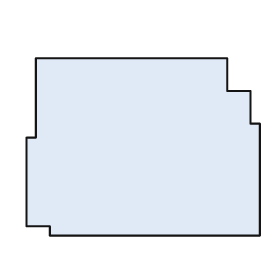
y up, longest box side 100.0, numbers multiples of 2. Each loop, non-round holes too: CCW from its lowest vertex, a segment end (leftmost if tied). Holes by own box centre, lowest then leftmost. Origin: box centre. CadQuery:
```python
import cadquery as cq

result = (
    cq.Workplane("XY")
    .moveTo(-40.0, -38.0)
    .lineTo(50.0, -38.0)
    .lineTo(50.0, 10.0)
    .lineTo(46.0, 10.0)
    .lineTo(46.0, 24.0)
    .lineTo(36.0, 24.0)
    .lineTo(36.0, 38.0)
    .lineTo(-46.0, 38.0)
    .lineTo(-46.0, 4.0)
    .lineTo(-50.0, 4.0)
    .lineTo(-50.0, -34.0)
    .lineTo(-40.0, -34.0)
    .close()
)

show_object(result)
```